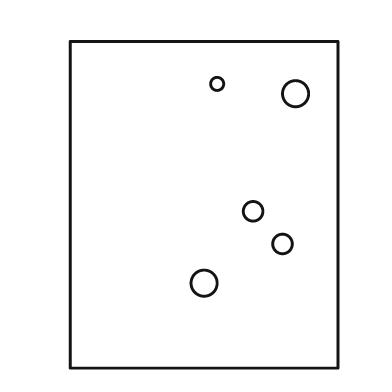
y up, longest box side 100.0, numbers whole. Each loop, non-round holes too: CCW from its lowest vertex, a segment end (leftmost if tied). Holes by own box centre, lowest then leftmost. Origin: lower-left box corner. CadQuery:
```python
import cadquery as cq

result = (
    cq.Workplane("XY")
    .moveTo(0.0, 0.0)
    .lineTo(82.0, 0.0)
    .lineTo(82.0, 100.0)
    .lineTo(0.0, 100.0)
    .close()
    .moveTo(41.0, 26.0)
    .circle(4.0)
    .moveTo(65.0, 38.0)
    .circle(3.0)
    .moveTo(56.0, 48.0)
    .circle(3.0)
    .moveTo(69.0, 84.0)
    .circle(4.0)
    .moveTo(45.0, 87.0)
    .circle(2.0)
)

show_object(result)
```